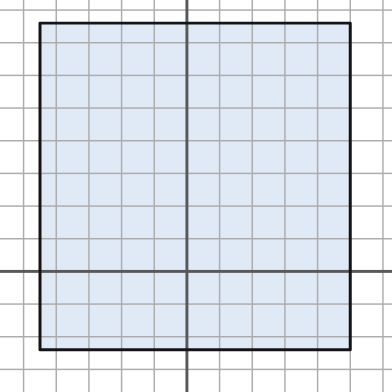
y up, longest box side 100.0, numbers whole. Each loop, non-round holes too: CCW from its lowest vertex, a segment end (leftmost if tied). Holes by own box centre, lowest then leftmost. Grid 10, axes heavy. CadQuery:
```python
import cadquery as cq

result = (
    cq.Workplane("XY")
    .moveTo(-45.0, -24.0)
    .lineTo(50.0, -24.0)
    .lineTo(50.0, 76.0)
    .lineTo(-45.0, 76.0)
    .close()
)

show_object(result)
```